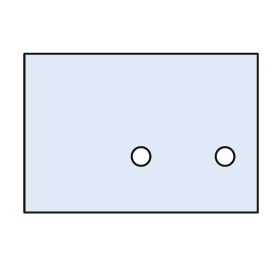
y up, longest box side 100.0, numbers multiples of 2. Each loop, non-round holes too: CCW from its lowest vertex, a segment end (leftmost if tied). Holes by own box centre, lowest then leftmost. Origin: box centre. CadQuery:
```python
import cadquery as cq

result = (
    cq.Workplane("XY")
    .moveTo(-50.0, -34.0)
    .lineTo(50.0, -34.0)
    .lineTo(50.0, 34.0)
    .lineTo(-50.0, 34.0)
    .close()
    .moveTo(0.0, -10.0)
    .circle(4.0)
    .moveTo(36.0, -10.0)
    .circle(4.0)
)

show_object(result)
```